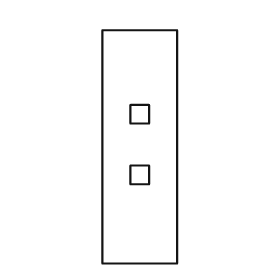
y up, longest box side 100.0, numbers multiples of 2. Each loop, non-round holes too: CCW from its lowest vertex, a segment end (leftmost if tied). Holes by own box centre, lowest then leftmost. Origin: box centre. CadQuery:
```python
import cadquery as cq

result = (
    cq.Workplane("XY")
    .moveTo(-16.0, -50.0)
    .lineTo(16.0, -50.0)
    .lineTo(16.0, 50.0)
    .lineTo(-16.0, 50.0)
    .close()
    .moveTo(-4.0, -16.0)
    .lineTo(4.0, -16.0)
    .lineTo(4.0, -8.0)
    .lineTo(-4.0, -8.0)
    .close()
    .moveTo(-4.0, 10.0)
    .lineTo(4.0, 10.0)
    .lineTo(4.0, 18.0)
    .lineTo(-4.0, 18.0)
    .close()
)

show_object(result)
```